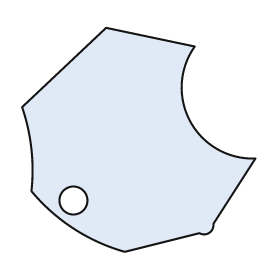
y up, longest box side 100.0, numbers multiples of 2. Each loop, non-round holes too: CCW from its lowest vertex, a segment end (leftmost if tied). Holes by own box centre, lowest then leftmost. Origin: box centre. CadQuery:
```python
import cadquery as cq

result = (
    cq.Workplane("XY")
    .moveTo(-6.0, -48.0)
    .lineTo(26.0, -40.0)
    .threePointArc((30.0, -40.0), (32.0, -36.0))
    .lineTo(50.0, -8.0)
    .threePointArc((22.0, 8.0), (24.0, 40.0))
    .lineTo(-14.0, 48.0)
    .lineTo(-50.0, 14.0)
    .threePointArc((-46.0, -4.0), (-46.0, -22.0))
    .threePointArc((-28.0, -38.0), (-6.0, -48.0))
    .close()
    .moveTo(-28.0, -26.0)
    .circle(6.0)
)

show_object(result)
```